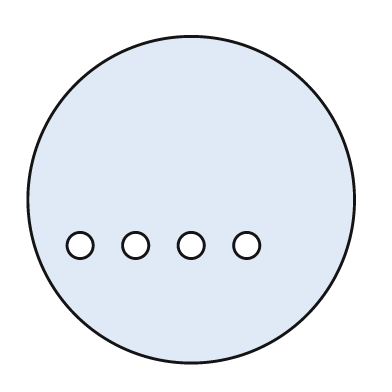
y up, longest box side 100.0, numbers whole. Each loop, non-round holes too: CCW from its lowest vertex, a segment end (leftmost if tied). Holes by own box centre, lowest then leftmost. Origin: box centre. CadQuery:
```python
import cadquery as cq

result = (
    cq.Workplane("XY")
    .moveTo(0.0, 0.0)
    .circle(50.0)
    .moveTo(-34.0, -14.0)
    .circle(4.0)
    .moveTo(-17.0, -14.0)
    .circle(4.0)
    .moveTo(0.0, -14.0)
    .circle(4.0)
    .moveTo(17.0, -14.0)
    .circle(4.0)
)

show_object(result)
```